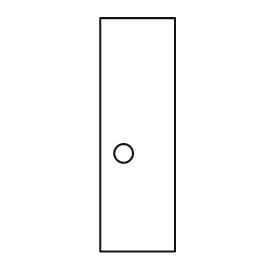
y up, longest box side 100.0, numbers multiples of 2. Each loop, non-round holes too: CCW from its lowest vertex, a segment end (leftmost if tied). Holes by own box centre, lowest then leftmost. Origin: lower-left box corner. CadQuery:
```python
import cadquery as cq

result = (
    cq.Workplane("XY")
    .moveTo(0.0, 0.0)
    .lineTo(32.0, 0.0)
    .lineTo(32.0, 100.0)
    .lineTo(0.0, 100.0)
    .close()
    .moveTo(10.0, 42.0)
    .circle(4.0)
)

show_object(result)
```